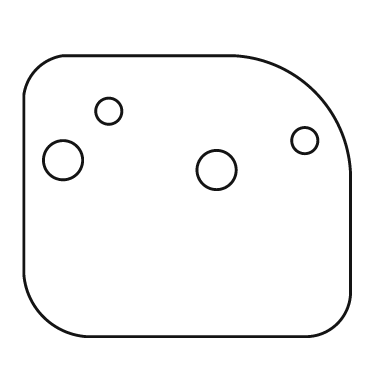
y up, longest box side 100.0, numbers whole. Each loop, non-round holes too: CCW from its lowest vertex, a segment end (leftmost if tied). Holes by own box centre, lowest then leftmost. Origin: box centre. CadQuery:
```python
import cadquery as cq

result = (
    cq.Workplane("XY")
    .moveTo(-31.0, -43.0)
    .lineTo(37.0, -43.0)
    .threePointArc((46.0, -39.0), (50.0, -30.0))
    .lineTo(50.0, 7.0)
    .threePointArc((39.0, 32.0), (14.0, 43.0))
    .lineTo(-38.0, 43.0)
    .threePointArc((-46.0, 39.0), (-50.0, 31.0))
    .lineTo(-50.0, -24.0)
    .threePointArc((-44.0, -37.0), (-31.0, -43.0))
    .close()
    .moveTo(9.0, 8.0)
    .circle(6.0)
    .moveTo(-38.0, 11.0)
    .circle(6.0)
    .moveTo(36.0, 17.0)
    .circle(4.0)
    .moveTo(-24.0, 26.0)
    .circle(4.0)
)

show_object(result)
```